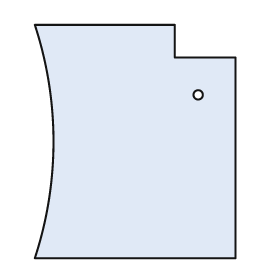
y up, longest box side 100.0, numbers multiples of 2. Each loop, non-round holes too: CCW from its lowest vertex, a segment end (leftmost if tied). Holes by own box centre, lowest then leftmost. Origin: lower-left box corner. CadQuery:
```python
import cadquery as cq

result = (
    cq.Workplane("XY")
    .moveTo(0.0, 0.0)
    .lineTo(86.0, 0.0)
    .lineTo(86.0, 86.0)
    .lineTo(60.0, 86.0)
    .lineTo(60.0, 100.0)
    .lineTo(0.0, 100.0)
    .threePointArc((8.0, 50.0), (0.0, 0.0))
    .close()
    .moveTo(70.0, 70.0)
    .circle(2.0)
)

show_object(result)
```